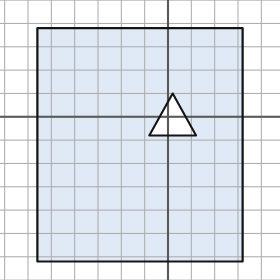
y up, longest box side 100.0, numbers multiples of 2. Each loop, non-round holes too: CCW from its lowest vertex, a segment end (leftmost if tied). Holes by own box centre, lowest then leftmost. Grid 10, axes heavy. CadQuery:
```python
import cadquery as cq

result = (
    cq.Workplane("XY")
    .moveTo(-56.0, -62.0)
    .lineTo(32.0, -62.0)
    .lineTo(32.0, 38.0)
    .lineTo(-56.0, 38.0)
    .close()
    .moveTo(-8.0, -8.0)
    .lineTo(12.0, -8.0)
    .lineTo(2.0, 10.0)
    .close()
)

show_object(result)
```